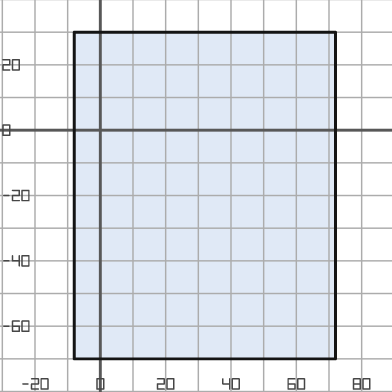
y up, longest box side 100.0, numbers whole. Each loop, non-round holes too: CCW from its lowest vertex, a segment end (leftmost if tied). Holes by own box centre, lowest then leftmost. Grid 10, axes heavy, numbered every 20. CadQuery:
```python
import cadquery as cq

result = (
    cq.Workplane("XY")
    .moveTo(-8.0, -70.0)
    .lineTo(72.0, -70.0)
    .lineTo(72.0, 30.0)
    .lineTo(-8.0, 30.0)
    .close()
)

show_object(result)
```